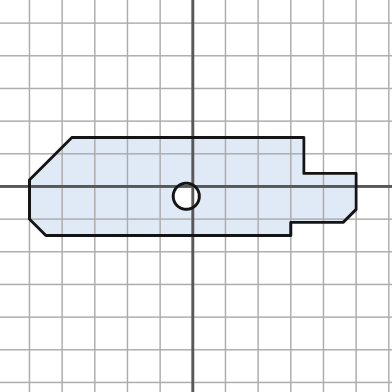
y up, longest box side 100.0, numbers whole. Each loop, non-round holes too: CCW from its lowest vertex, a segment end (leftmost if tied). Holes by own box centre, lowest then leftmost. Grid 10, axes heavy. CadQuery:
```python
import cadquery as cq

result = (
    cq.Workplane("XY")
    .moveTo(-45.0, -15.0)
    .lineTo(30.0, -15.0)
    .lineTo(30.0, -11.0)
    .lineTo(46.0, -11.0)
    .lineTo(50.0, -7.0)
    .lineTo(50.0, 4.0)
    .lineTo(34.0, 4.0)
    .lineTo(34.0, 15.0)
    .lineTo(-37.0, 15.0)
    .lineTo(-50.0, 2.0)
    .lineTo(-50.0, -10.0)
    .close()
    .moveTo(-2.0, -3.0)
    .circle(4.0)
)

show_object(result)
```